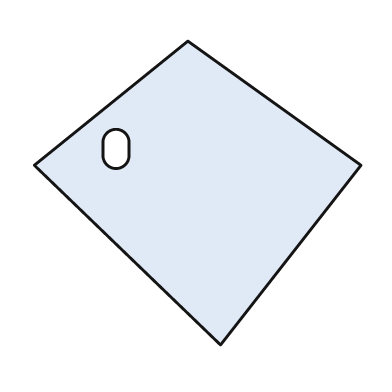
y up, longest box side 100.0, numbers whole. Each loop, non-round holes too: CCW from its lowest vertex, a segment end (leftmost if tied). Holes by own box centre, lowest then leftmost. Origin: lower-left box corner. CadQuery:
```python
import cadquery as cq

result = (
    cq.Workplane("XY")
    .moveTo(57.0, 0.0)
    .lineTo(100.0, 55.0)
    .lineTo(47.0, 93.0)
    .lineTo(0.0, 55.0)
    .close()
    .moveTo(21.0, 58.0)
    .threePointArc((25.0, 54.0), (29.0, 58.0))
    .lineTo(29.0, 62.0)
    .threePointArc((25.0, 66.0), (21.0, 62.0))
    .close()
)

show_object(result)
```